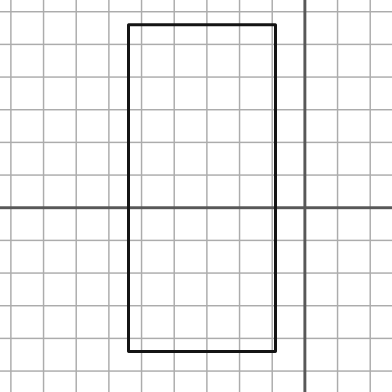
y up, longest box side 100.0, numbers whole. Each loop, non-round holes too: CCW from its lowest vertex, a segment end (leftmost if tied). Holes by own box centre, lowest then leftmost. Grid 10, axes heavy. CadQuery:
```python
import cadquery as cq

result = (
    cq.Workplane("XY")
    .moveTo(-54.0, -44.0)
    .lineTo(-9.0, -44.0)
    .lineTo(-9.0, 56.0)
    .lineTo(-54.0, 56.0)
    .close()
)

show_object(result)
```